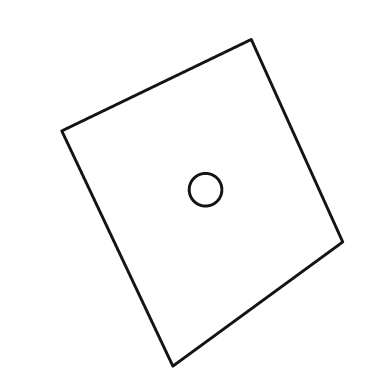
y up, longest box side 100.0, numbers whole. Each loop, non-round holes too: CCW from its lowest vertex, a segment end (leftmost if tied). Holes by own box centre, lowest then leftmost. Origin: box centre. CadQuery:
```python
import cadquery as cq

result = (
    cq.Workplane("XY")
    .moveTo(-9.0, -50.0)
    .lineTo(43.0, -12.0)
    .lineTo(15.0, 50.0)
    .lineTo(-43.0, 22.0)
    .close()
    .moveTo(1.0, 4.0)
    .circle(5.0)
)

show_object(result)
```